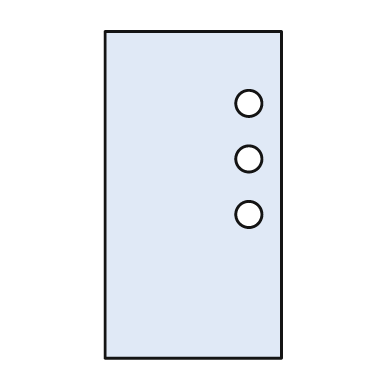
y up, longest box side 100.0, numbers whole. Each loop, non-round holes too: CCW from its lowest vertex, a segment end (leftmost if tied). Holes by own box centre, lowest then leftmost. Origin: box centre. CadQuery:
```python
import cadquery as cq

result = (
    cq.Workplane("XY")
    .moveTo(-27.0, -50.0)
    .lineTo(27.0, -50.0)
    .lineTo(27.0, 50.0)
    .lineTo(-27.0, 50.0)
    .close()
    .moveTo(17.0, -6.0)
    .circle(4.0)
    .moveTo(17.0, 11.0)
    .circle(4.0)
    .moveTo(17.0, 28.0)
    .circle(4.0)
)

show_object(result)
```